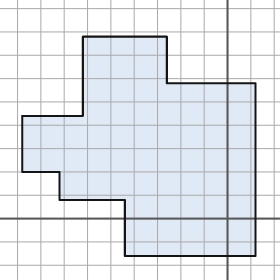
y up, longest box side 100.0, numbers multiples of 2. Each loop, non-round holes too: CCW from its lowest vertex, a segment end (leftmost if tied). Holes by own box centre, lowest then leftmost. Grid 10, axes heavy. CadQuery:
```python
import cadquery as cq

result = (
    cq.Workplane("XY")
    .moveTo(-44.0, -16.0)
    .lineTo(12.0, -16.0)
    .lineTo(12.0, 58.0)
    .lineTo(-26.0, 58.0)
    .lineTo(-26.0, 78.0)
    .lineTo(-62.0, 78.0)
    .lineTo(-62.0, 44.0)
    .lineTo(-88.0, 44.0)
    .lineTo(-88.0, 20.0)
    .lineTo(-72.0, 20.0)
    .lineTo(-72.0, 8.0)
    .lineTo(-44.0, 8.0)
    .close()
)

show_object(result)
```